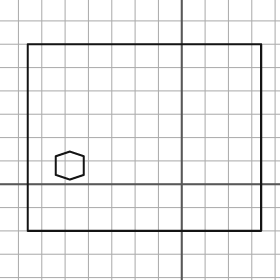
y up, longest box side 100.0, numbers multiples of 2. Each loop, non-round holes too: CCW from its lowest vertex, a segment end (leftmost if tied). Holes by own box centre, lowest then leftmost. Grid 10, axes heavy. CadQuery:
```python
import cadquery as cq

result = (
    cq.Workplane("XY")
    .moveTo(-66.0, -20.0)
    .lineTo(34.0, -20.0)
    .lineTo(34.0, 60.0)
    .lineTo(-66.0, 60.0)
    .close()
    .moveTo(-48.0, 2.0)
    .lineTo(-42.0, 4.0)
    .lineTo(-42.0, 12.0)
    .lineTo(-48.0, 14.0)
    .lineTo(-54.0, 12.0)
    .lineTo(-54.0, 4.0)
    .close()
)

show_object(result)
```